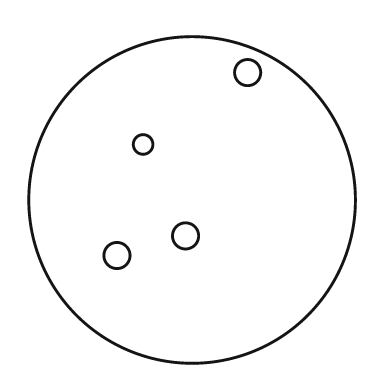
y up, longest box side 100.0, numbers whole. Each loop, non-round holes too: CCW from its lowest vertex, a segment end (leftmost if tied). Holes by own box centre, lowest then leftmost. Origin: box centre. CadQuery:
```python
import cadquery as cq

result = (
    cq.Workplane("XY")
    .moveTo(0.0, 0.0)
    .circle(50.0)
    .moveTo(-23.0, -17.0)
    .circle(4.0)
    .moveTo(-2.0, -11.0)
    .circle(4.0)
    .moveTo(-15.0, 17.0)
    .circle(3.0)
    .moveTo(17.0, 39.0)
    .circle(4.0)
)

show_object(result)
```